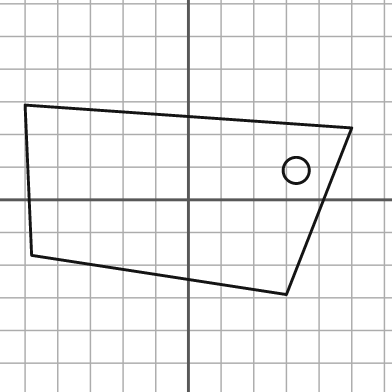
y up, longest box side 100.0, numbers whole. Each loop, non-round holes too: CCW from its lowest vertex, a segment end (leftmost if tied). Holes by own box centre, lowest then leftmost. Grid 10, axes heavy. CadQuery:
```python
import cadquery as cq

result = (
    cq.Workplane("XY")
    .moveTo(30.0, -29.0)
    .lineTo(50.0, 22.0)
    .lineTo(-50.0, 29.0)
    .lineTo(-48.0, -17.0)
    .close()
    .moveTo(33.0, 9.0)
    .circle(4.0)
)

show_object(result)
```